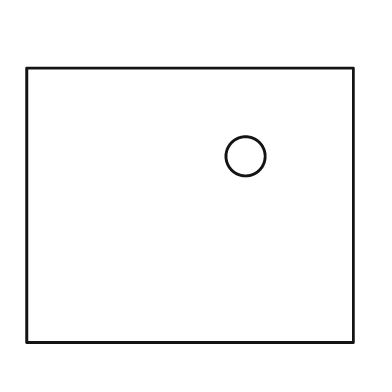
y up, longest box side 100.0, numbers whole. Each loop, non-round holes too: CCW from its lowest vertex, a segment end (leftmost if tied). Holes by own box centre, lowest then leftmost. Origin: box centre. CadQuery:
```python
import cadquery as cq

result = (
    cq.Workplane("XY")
    .moveTo(-50.0, -42.0)
    .lineTo(50.0, -42.0)
    .lineTo(50.0, 42.0)
    .lineTo(-50.0, 42.0)
    .close()
    .moveTo(17.0, 15.0)
    .circle(6.0)
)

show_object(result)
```